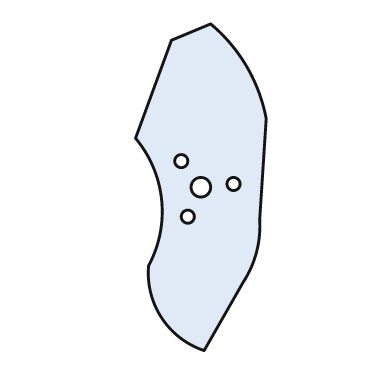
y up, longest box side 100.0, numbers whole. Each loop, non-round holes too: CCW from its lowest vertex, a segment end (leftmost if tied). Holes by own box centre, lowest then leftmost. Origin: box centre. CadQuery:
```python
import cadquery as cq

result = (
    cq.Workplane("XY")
    .moveTo(1.0, -50.0)
    .lineTo(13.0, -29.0)
    .threePointArc((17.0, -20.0), (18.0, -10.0))
    .lineTo(20.0, 21.0)
    .threePointArc((14.0, 37.0), (3.0, 50.0))
    .lineTo(-9.0, 45.0)
    .lineTo(-20.0, 15.0)
    .threePointArc((-12.0, -4.0), (-16.0, -24.0))
    .threePointArc((-12.0, -40.0), (1.0, -50.0))
    .close()
    .moveTo(-4.0, -9.0)
    .circle(2.0)
    .moveTo(0.0, 0.0)
    .circle(3.0)
    .moveTo(10.0, 1.0)
    .circle(2.0)
    .moveTo(-6.0, 8.0)
    .circle(2.0)
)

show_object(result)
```